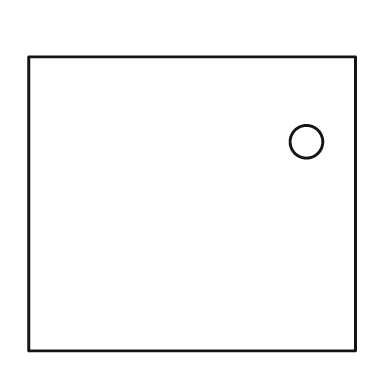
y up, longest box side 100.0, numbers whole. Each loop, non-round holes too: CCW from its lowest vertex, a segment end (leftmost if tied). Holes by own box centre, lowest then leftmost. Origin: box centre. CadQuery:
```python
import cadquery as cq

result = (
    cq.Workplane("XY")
    .moveTo(-50.0, -45.0)
    .lineTo(50.0, -45.0)
    .lineTo(50.0, 45.0)
    .lineTo(-50.0, 45.0)
    .close()
    .moveTo(35.0, 19.0)
    .circle(5.0)
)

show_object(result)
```